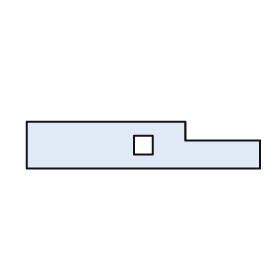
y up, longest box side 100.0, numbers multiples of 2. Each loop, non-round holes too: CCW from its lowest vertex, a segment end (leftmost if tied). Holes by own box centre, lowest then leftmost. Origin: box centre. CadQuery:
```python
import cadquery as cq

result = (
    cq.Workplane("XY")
    .moveTo(-50.0, -10.0)
    .lineTo(50.0, -10.0)
    .lineTo(50.0, 2.0)
    .lineTo(18.0, 2.0)
    .lineTo(18.0, 10.0)
    .lineTo(-50.0, 10.0)
    .close()
    .moveTo(-4.0, -4.0)
    .lineTo(4.0, -4.0)
    .lineTo(4.0, 4.0)
    .lineTo(-4.0, 4.0)
    .close()
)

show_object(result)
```